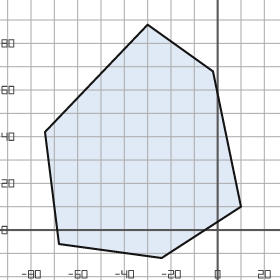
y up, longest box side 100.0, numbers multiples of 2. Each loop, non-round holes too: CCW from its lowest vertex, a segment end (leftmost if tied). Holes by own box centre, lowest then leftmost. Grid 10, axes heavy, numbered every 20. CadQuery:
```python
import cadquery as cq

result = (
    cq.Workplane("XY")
    .moveTo(-24.0, -12.0)
    .lineTo(10.0, 10.0)
    .lineTo(-2.0, 68.0)
    .lineTo(-30.0, 88.0)
    .lineTo(-74.0, 42.0)
    .lineTo(-68.0, -6.0)
    .close()
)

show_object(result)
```